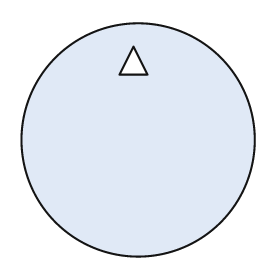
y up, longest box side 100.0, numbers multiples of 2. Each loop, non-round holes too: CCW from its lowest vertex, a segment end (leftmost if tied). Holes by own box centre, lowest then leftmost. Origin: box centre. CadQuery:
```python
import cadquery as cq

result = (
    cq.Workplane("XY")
    .moveTo(0.0, 0.0)
    .circle(50.0)
    .moveTo(-8.0, 28.0)
    .lineTo(4.0, 28.0)
    .lineTo(-2.0, 40.0)
    .close()
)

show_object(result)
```